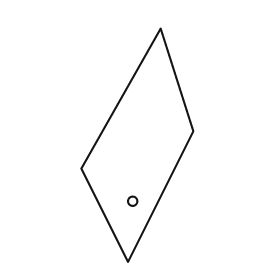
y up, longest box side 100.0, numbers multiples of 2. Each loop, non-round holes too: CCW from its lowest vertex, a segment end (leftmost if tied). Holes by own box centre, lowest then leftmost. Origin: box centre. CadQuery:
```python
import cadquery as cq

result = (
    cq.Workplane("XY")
    .moveTo(-4.0, -50.0)
    .lineTo(24.0, 6.0)
    .lineTo(10.0, 50.0)
    .lineTo(-24.0, -10.0)
    .close()
    .moveTo(-2.0, -24.0)
    .circle(2.0)
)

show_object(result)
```